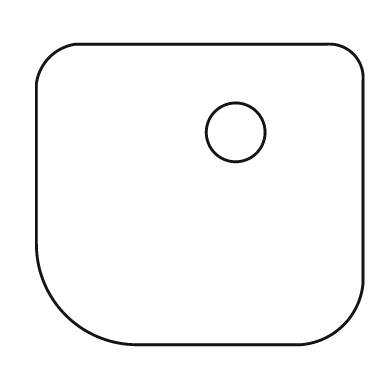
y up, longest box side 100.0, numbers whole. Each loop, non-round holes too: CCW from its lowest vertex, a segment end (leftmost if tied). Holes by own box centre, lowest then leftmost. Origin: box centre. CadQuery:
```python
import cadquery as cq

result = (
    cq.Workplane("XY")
    .moveTo(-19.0, -46.0)
    .lineTo(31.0, -46.0)
    .threePointArc((44.0, -40.0), (50.0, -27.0))
    .lineTo(50.0, 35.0)
    .threePointArc((47.0, 43.0), (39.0, 46.0))
    .lineTo(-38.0, 46.0)
    .threePointArc((-46.0, 42.0), (-50.0, 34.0))
    .lineTo(-50.0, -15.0)
    .threePointArc((-41.0, -37.0), (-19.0, -46.0))
    .close()
    .moveTo(11.0, 19.0)
    .circle(9.0)
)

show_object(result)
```